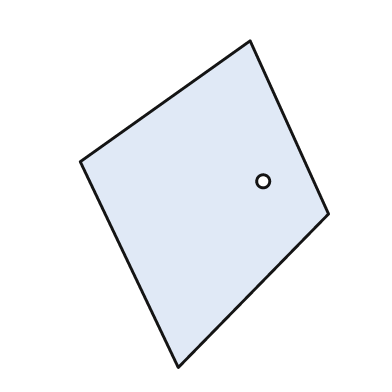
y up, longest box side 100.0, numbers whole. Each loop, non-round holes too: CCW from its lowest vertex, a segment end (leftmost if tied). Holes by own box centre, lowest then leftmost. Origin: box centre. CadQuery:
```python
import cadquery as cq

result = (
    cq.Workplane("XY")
    .moveTo(-8.0, -50.0)
    .lineTo(38.0, -3.0)
    .lineTo(14.0, 50.0)
    .lineTo(-38.0, 13.0)
    .close()
    .moveTo(18.0, 7.0)
    .circle(2.0)
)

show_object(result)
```